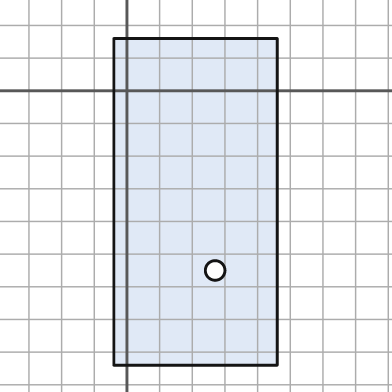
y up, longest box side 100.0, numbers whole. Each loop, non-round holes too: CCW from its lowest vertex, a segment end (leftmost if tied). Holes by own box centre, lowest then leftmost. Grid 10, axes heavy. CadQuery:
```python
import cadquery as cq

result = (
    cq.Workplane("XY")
    .moveTo(-4.0, -84.0)
    .lineTo(46.0, -84.0)
    .lineTo(46.0, 16.0)
    .lineTo(-4.0, 16.0)
    .close()
    .moveTo(27.0, -55.0)
    .circle(3.0)
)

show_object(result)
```